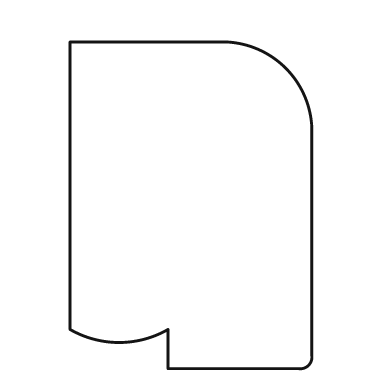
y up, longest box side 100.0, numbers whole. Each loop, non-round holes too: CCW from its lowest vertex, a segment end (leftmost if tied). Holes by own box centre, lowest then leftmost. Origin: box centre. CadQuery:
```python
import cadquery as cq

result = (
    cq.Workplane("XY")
    .moveTo(-7.0, -50.0)
    .lineTo(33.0, -50.0)
    .threePointArc((36.0, -49.0), (37.0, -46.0))
    .lineTo(37.0, 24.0)
    .threePointArc((29.0, 42.0), (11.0, 50.0))
    .lineTo(-37.0, 50.0)
    .lineTo(-37.0, -38.0)
    .threePointArc((-22.0, -42.0), (-7.0, -38.0))
    .close()
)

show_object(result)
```